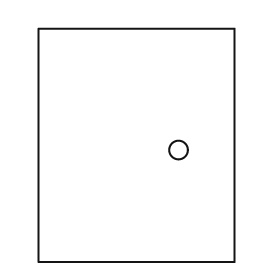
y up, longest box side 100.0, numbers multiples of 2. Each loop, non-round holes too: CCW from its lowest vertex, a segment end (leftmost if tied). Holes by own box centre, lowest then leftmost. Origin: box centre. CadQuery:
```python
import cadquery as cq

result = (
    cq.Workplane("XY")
    .moveTo(-42.0, -50.0)
    .lineTo(42.0, -50.0)
    .lineTo(42.0, 50.0)
    .lineTo(-42.0, 50.0)
    .close()
    .moveTo(18.0, -2.0)
    .circle(4.0)
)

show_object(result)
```